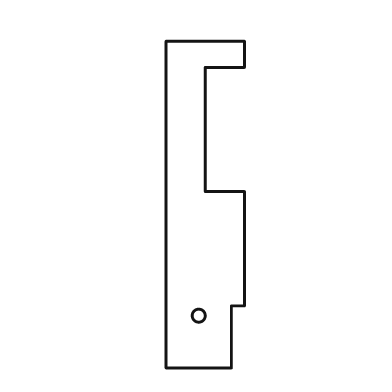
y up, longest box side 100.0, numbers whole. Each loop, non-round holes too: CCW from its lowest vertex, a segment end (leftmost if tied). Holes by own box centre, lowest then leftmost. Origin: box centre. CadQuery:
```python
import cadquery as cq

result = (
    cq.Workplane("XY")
    .moveTo(-12.0, -50.0)
    .lineTo(8.0, -50.0)
    .lineTo(8.0, -31.0)
    .lineTo(12.0, -31.0)
    .lineTo(12.0, 4.0)
    .lineTo(0.0, 4.0)
    .lineTo(0.0, 42.0)
    .lineTo(12.0, 42.0)
    .lineTo(12.0, 50.0)
    .lineTo(-12.0, 50.0)
    .close()
    .moveTo(-2.0, -34.0)
    .circle(2.0)
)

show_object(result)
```